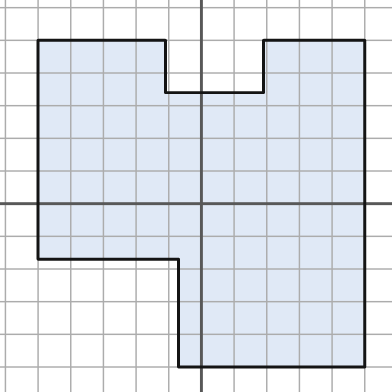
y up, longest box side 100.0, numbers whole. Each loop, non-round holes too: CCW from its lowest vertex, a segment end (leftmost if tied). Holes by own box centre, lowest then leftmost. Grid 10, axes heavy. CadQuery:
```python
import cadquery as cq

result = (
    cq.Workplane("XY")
    .moveTo(-7.0, -50.0)
    .lineTo(50.0, -50.0)
    .lineTo(50.0, 50.0)
    .lineTo(19.0, 50.0)
    .lineTo(19.0, 34.0)
    .lineTo(-11.0, 34.0)
    .lineTo(-11.0, 50.0)
    .lineTo(-50.0, 50.0)
    .lineTo(-50.0, -17.0)
    .lineTo(-7.0, -17.0)
    .close()
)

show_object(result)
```